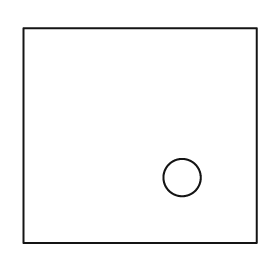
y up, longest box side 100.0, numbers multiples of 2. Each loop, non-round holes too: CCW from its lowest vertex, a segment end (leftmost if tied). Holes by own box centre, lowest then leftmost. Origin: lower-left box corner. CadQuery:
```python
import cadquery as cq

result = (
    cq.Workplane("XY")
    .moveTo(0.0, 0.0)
    .lineTo(100.0, 0.0)
    .lineTo(100.0, 92.0)
    .lineTo(0.0, 92.0)
    .close()
    .moveTo(68.0, 28.0)
    .circle(8.0)
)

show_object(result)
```